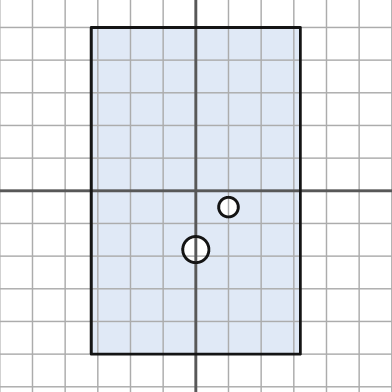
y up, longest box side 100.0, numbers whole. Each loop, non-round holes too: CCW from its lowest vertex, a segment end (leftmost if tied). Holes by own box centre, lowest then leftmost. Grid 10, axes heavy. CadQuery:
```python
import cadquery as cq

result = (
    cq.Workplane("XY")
    .moveTo(-32.0, -50.0)
    .lineTo(32.0, -50.0)
    .lineTo(32.0, 50.0)
    .lineTo(-32.0, 50.0)
    .close()
    .moveTo(0.0, -18.0)
    .circle(4.0)
    .moveTo(10.0, -5.0)
    .circle(3.0)
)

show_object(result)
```